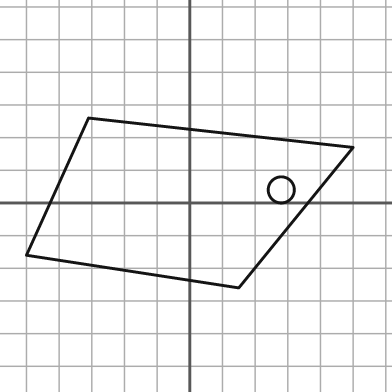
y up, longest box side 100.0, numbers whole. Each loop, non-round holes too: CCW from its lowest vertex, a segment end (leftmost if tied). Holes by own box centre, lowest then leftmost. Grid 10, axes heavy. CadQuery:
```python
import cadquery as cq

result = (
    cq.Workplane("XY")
    .moveTo(15.0, -26.0)
    .lineTo(50.0, 17.0)
    .lineTo(-31.0, 26.0)
    .lineTo(-50.0, -16.0)
    .close()
    .moveTo(28.0, 4.0)
    .circle(4.0)
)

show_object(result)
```